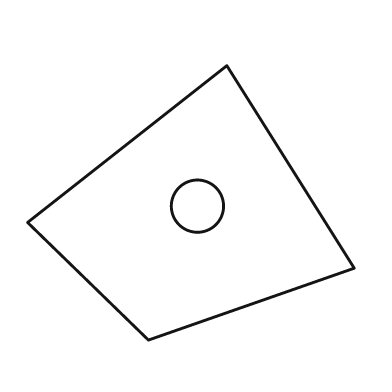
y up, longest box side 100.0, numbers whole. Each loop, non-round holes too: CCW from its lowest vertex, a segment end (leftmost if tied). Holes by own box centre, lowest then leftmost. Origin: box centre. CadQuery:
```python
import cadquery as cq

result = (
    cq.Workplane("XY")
    .moveTo(-13.0, -42.0)
    .lineTo(50.0, -20.0)
    .lineTo(11.0, 42.0)
    .lineTo(-50.0, -6.0)
    .close()
    .moveTo(2.0, -1.0)
    .circle(8.0)
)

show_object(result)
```